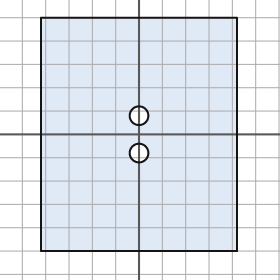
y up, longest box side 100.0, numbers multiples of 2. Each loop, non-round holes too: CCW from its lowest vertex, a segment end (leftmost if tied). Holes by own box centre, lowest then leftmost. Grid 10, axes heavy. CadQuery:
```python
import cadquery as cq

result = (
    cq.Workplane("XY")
    .moveTo(-42.0, -50.0)
    .lineTo(42.0, -50.0)
    .lineTo(42.0, 50.0)
    .lineTo(-42.0, 50.0)
    .close()
    .moveTo(0.0, -8.0)
    .circle(4.0)
    .moveTo(0.0, 8.0)
    .circle(4.0)
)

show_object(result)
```